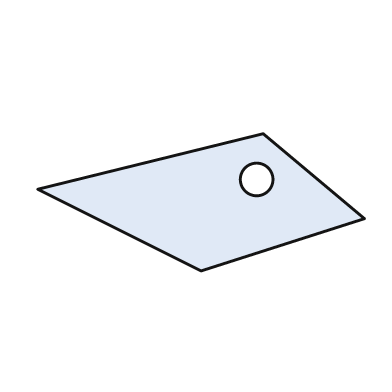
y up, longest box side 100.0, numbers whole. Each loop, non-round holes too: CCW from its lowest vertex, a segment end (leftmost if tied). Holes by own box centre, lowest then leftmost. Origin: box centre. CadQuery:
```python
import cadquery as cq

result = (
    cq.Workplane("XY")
    .moveTo(0.0, -21.0)
    .lineTo(50.0, -5.0)
    .lineTo(19.0, 21.0)
    .lineTo(-50.0, 4.0)
    .close()
    .moveTo(17.0, 7.0)
    .circle(5.0)
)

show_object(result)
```